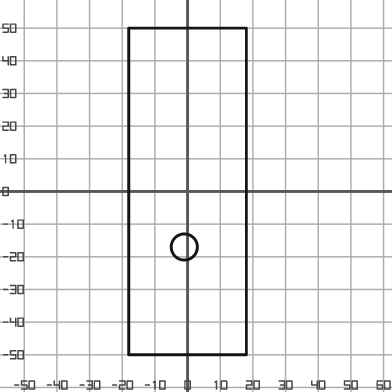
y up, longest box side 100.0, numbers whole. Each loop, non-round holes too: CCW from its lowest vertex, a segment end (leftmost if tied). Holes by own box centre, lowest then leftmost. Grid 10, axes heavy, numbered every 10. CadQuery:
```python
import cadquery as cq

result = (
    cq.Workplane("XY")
    .moveTo(-18.0, -50.0)
    .lineTo(18.0, -50.0)
    .lineTo(18.0, 50.0)
    .lineTo(-18.0, 50.0)
    .close()
    .moveTo(-1.0, -17.0)
    .circle(4.0)
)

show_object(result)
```